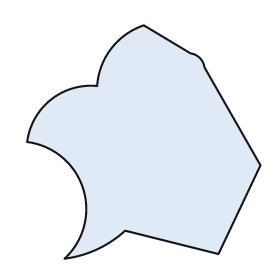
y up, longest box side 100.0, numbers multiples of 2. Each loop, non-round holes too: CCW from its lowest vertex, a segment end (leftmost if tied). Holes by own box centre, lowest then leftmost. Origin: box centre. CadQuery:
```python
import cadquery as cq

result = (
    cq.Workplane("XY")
    .moveTo(-34.0, -50.0)
    .threePointArc((-20.0, -46.0), (-8.0, -38.0))
    .lineTo(32.0, -48.0)
    .lineTo(50.0, -10.0)
    .lineTo(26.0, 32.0)
    .threePointArc((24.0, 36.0), (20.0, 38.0))
    .lineTo(0.0, 50.0)
    .threePointArc((-14.0, 40.0), (-20.0, 24.0))
    .threePointArc((-40.0, 18.0), (-50.0, 0.0))
    .threePointArc((-26.0, -20.0), (-34.0, -50.0))
    .close()
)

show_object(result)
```